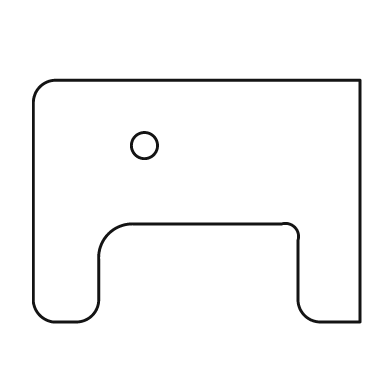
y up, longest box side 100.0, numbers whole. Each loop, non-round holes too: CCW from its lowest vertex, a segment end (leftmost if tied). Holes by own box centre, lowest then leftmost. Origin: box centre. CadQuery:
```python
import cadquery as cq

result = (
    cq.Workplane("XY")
    .moveTo(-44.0, -37.0)
    .lineTo(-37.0, -37.0)
    .threePointArc((-32.0, -35.0), (-30.0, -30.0))
    .lineTo(-30.0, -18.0)
    .threePointArc((-27.0, -10.0), (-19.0, -7.0))
    .lineTo(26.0, -7.0)
    .threePointArc((30.0, -8.0), (31.0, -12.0))
    .lineTo(31.0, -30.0)
    .threePointArc((33.0, -35.0), (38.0, -37.0))
    .lineTo(50.0, -37.0)
    .lineTo(50.0, 37.0)
    .lineTo(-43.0, 37.0)
    .threePointArc((-48.0, 35.0), (-50.0, 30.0))
    .lineTo(-50.0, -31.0)
    .threePointArc((-48.0, -35.0), (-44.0, -37.0))
    .close()
    .moveTo(-16.0, 17.0)
    .circle(4.0)
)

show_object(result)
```